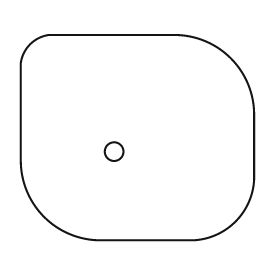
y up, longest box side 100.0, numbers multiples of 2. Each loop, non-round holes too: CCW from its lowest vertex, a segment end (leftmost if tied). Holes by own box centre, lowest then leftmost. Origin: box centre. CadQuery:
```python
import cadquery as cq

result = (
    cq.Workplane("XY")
    .moveTo(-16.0, -44.0)
    .lineTo(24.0, -44.0)
    .threePointArc((42.0, -36.0), (50.0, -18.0))
    .lineTo(50.0, 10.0)
    .threePointArc((40.0, 34.0), (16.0, 44.0))
    .lineTo(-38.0, 44.0)
    .threePointArc((-46.0, 40.0), (-50.0, 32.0))
    .lineTo(-50.0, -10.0)
    .threePointArc((-40.0, -34.0), (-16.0, -44.0))
    .close()
    .moveTo(-10.0, -6.0)
    .circle(4.0)
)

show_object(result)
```